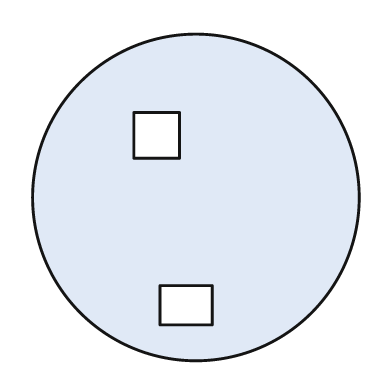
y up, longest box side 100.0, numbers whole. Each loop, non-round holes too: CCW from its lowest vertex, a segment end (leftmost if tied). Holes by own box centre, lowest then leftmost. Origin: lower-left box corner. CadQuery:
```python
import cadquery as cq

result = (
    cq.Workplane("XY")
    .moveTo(50.0, 50.0)
    .circle(50.0)
    .moveTo(39.0, 11.0)
    .lineTo(55.0, 11.0)
    .lineTo(55.0, 23.0)
    .lineTo(39.0, 23.0)
    .close()
    .moveTo(31.0, 62.0)
    .lineTo(45.0, 62.0)
    .lineTo(45.0, 76.0)
    .lineTo(31.0, 76.0)
    .close()
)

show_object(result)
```